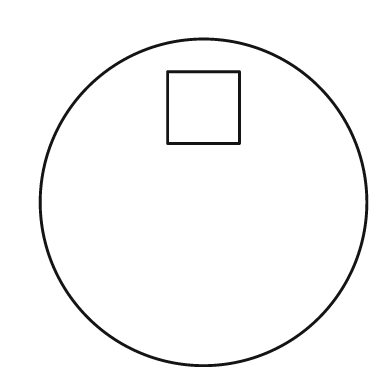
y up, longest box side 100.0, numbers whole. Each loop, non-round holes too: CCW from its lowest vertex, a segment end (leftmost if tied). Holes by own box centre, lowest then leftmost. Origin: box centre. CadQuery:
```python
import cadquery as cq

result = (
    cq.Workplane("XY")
    .moveTo(0.0, 0.0)
    .circle(50.0)
    .moveTo(-11.0, 18.0)
    .lineTo(11.0, 18.0)
    .lineTo(11.0, 40.0)
    .lineTo(-11.0, 40.0)
    .close()
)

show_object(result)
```